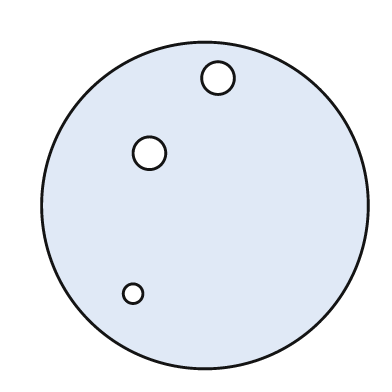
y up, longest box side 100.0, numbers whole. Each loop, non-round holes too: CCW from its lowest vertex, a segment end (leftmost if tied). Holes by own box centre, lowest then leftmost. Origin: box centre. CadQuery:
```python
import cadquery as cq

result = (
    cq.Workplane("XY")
    .moveTo(0.0, 0.0)
    .circle(50.0)
    .moveTo(-22.0, -27.0)
    .circle(3.0)
    .moveTo(-17.0, 16.0)
    .circle(5.0)
    .moveTo(4.0, 39.0)
    .circle(5.0)
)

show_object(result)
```